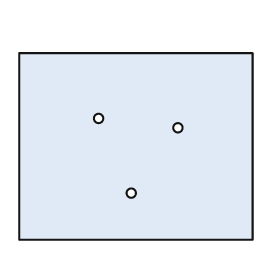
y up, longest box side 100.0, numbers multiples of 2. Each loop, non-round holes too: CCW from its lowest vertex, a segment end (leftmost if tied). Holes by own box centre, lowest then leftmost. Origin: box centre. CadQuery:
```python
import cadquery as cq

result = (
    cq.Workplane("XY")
    .moveTo(-50.0, -40.0)
    .lineTo(50.0, -40.0)
    .lineTo(50.0, 40.0)
    .lineTo(-50.0, 40.0)
    .close()
    .moveTo(-2.0, -20.0)
    .circle(2.0)
    .moveTo(18.0, 8.0)
    .circle(2.0)
    .moveTo(-16.0, 12.0)
    .circle(2.0)
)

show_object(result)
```